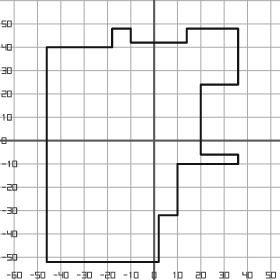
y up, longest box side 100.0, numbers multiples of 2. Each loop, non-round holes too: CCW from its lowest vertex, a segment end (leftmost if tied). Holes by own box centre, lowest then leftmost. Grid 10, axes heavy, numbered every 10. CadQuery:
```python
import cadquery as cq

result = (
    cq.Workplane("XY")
    .moveTo(-46.0, -52.0)
    .lineTo(2.0, -52.0)
    .lineTo(2.0, -32.0)
    .lineTo(10.0, -32.0)
    .lineTo(10.0, -10.0)
    .lineTo(36.0, -10.0)
    .lineTo(36.0, -6.0)
    .lineTo(20.0, -6.0)
    .lineTo(20.0, 24.0)
    .lineTo(36.0, 24.0)
    .lineTo(36.0, 48.0)
    .lineTo(14.0, 48.0)
    .lineTo(14.0, 42.0)
    .lineTo(-10.0, 42.0)
    .lineTo(-10.0, 48.0)
    .lineTo(-18.0, 48.0)
    .lineTo(-18.0, 40.0)
    .lineTo(-46.0, 40.0)
    .close()
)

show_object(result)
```